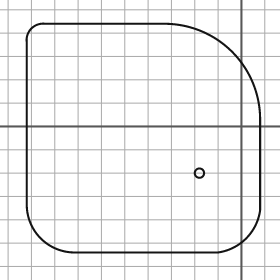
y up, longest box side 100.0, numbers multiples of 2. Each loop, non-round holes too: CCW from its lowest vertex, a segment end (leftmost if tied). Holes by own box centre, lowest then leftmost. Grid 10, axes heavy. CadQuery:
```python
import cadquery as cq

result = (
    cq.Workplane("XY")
    .moveTo(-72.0, -54.0)
    .lineTo(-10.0, -54.0)
    .threePointArc((2.0, -48.0), (8.0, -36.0))
    .lineTo(8.0, 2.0)
    .threePointArc((-4.0, 32.0), (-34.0, 44.0))
    .lineTo(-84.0, 44.0)
    .threePointArc((-90.0, 42.0), (-92.0, 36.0))
    .lineTo(-92.0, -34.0)
    .threePointArc((-86.0, -48.0), (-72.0, -54.0))
    .close()
    .moveTo(-18.0, -20.0)
    .circle(2.0)
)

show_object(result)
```